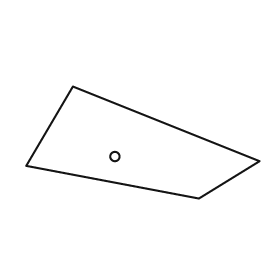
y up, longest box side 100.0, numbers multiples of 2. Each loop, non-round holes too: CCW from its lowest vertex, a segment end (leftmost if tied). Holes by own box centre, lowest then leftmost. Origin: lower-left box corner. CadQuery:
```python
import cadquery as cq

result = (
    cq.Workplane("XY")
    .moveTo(74.0, 0.0)
    .lineTo(100.0, 16.0)
    .lineTo(20.0, 48.0)
    .lineTo(0.0, 14.0)
    .close()
    .moveTo(38.0, 18.0)
    .circle(2.0)
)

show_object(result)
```